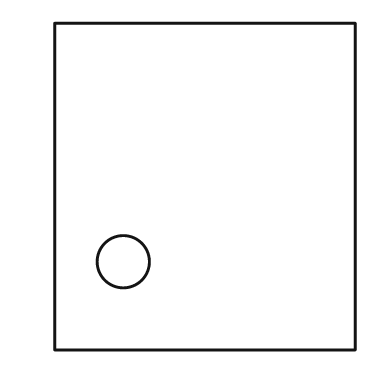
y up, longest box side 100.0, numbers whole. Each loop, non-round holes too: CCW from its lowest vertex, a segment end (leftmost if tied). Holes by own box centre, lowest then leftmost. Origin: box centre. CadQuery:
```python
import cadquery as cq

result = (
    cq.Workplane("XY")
    .moveTo(-46.0, -50.0)
    .lineTo(46.0, -50.0)
    .lineTo(46.0, 50.0)
    .lineTo(-46.0, 50.0)
    .close()
    .moveTo(-25.0, -23.0)
    .circle(8.0)
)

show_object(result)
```